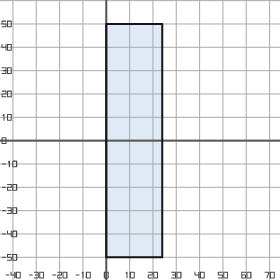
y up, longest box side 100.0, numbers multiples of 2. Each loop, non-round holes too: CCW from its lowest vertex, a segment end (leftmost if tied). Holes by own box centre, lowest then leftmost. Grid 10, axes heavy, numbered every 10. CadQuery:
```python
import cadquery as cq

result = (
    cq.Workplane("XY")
    .moveTo(0.0, -50.0)
    .lineTo(24.0, -50.0)
    .lineTo(24.0, 50.0)
    .lineTo(0.0, 50.0)
    .close()
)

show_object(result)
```